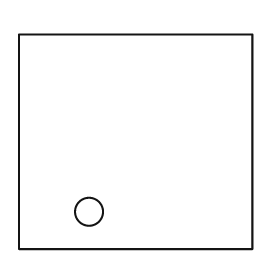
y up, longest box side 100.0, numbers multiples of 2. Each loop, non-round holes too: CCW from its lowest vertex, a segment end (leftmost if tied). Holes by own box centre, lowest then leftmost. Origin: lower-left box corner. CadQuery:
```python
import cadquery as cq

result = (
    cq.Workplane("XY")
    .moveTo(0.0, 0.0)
    .lineTo(100.0, 0.0)
    .lineTo(100.0, 92.0)
    .lineTo(0.0, 92.0)
    .close()
    .moveTo(30.0, 16.0)
    .circle(6.0)
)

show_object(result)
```